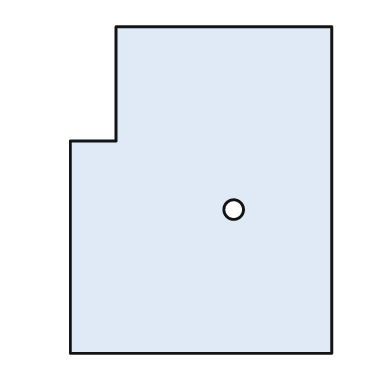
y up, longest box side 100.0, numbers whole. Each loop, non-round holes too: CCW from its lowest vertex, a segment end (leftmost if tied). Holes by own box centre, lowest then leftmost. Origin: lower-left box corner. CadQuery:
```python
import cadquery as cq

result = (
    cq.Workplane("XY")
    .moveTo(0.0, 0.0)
    .lineTo(80.0, 0.0)
    .lineTo(80.0, 100.0)
    .lineTo(14.0, 100.0)
    .lineTo(14.0, 65.0)
    .lineTo(0.0, 65.0)
    .close()
    .moveTo(50.0, 44.0)
    .circle(3.0)
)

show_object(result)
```